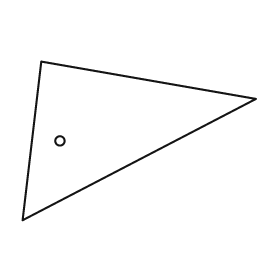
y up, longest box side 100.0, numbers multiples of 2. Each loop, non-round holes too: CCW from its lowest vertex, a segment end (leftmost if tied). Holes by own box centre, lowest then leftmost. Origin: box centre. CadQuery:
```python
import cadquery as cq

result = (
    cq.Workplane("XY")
    .moveTo(-50.0, -34.0)
    .lineTo(50.0, 18.0)
    .lineTo(-42.0, 34.0)
    .close()
    .moveTo(-34.0, 0.0)
    .circle(2.0)
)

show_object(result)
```